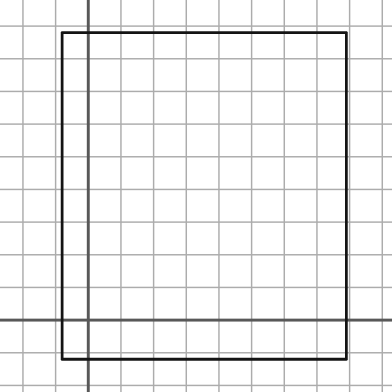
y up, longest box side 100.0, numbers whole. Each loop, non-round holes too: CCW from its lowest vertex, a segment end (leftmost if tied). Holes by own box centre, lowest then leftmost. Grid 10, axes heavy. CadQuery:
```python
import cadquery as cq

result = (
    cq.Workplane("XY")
    .moveTo(-8.0, -12.0)
    .lineTo(79.0, -12.0)
    .lineTo(79.0, 88.0)
    .lineTo(-8.0, 88.0)
    .close()
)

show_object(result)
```